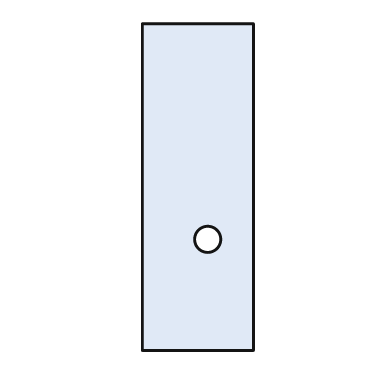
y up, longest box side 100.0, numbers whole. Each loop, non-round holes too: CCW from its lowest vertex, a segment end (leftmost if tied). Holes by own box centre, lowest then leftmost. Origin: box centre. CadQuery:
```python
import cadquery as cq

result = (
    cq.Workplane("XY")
    .moveTo(-17.0, -50.0)
    .lineTo(17.0, -50.0)
    .lineTo(17.0, 50.0)
    .lineTo(-17.0, 50.0)
    .close()
    .moveTo(3.0, -16.0)
    .circle(4.0)
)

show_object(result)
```